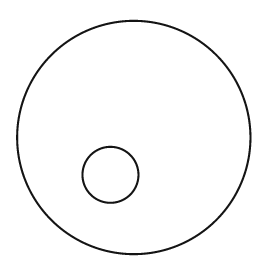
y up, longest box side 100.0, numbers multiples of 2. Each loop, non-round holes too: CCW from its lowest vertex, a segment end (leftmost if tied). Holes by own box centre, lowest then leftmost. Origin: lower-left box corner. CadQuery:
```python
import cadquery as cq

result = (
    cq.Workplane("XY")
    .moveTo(50.0, 50.0)
    .circle(50.0)
    .moveTo(40.0, 34.0)
    .circle(12.0)
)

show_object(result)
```